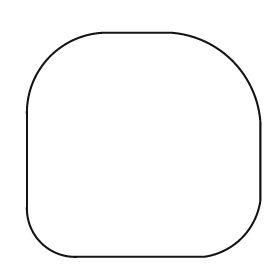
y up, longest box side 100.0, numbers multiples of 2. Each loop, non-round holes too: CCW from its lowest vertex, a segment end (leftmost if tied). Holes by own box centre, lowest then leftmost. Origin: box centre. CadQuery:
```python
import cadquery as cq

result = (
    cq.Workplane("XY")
    .moveTo(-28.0, -48.0)
    .lineTo(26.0, -48.0)
    .threePointArc((42.0, -40.0), (50.0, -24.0))
    .lineTo(50.0, 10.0)
    .threePointArc((38.0, 36.0), (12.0, 48.0))
    .lineTo(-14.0, 48.0)
    .threePointArc((-40.0, 38.0), (-50.0, 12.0))
    .lineTo(-50.0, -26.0)
    .threePointArc((-44.0, -42.0), (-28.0, -48.0))
    .close()
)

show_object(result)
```